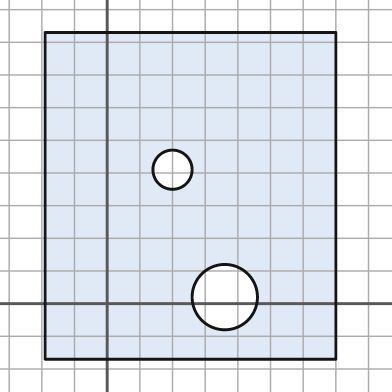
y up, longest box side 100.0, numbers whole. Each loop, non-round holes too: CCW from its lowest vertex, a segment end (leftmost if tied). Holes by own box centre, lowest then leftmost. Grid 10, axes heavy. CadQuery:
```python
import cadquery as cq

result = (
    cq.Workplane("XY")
    .moveTo(-19.0, -17.0)
    .lineTo(70.0, -17.0)
    .lineTo(70.0, 83.0)
    .lineTo(-19.0, 83.0)
    .close()
    .moveTo(36.0, 2.0)
    .circle(10.0)
    .moveTo(20.0, 41.0)
    .circle(6.0)
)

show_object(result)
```